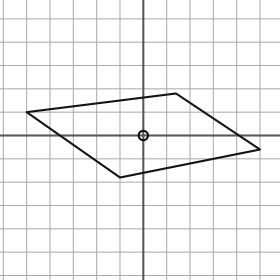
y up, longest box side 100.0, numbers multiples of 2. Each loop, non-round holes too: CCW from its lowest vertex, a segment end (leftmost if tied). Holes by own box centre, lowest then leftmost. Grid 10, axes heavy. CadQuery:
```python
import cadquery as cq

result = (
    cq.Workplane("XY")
    .moveTo(-10.0, -18.0)
    .lineTo(50.0, -6.0)
    .lineTo(14.0, 18.0)
    .lineTo(-50.0, 10.0)
    .close()
    .moveTo(0.0, 0.0)
    .circle(2.0)
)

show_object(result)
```